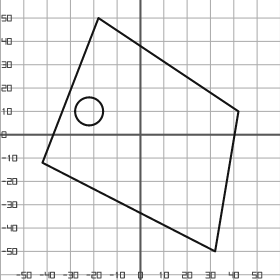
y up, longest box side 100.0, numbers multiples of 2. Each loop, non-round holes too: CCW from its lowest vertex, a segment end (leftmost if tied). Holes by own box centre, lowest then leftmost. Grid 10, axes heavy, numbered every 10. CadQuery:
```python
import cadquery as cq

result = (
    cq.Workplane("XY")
    .moveTo(32.0, -50.0)
    .lineTo(42.0, 10.0)
    .lineTo(-18.0, 50.0)
    .lineTo(-42.0, -12.0)
    .close()
    .moveTo(-22.0, 10.0)
    .circle(6.0)
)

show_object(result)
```